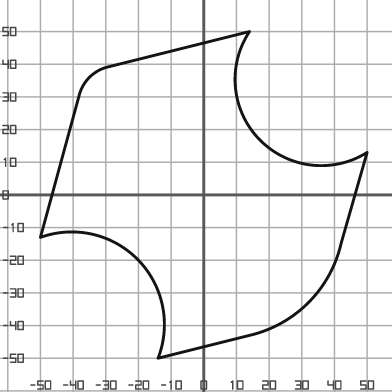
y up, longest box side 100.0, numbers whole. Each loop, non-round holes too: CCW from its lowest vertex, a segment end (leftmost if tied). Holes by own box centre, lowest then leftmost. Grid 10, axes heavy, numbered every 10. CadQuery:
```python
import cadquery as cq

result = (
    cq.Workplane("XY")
    .moveTo(-14.0, -50.0)
    .lineTo(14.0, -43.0)
    .threePointArc((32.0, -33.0), (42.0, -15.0))
    .lineTo(50.0, 13.0)
    .threePointArc((17.0, 17.0), (14.0, 50.0))
    .lineTo(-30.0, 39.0)
    .threePointArc((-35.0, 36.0), (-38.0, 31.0))
    .lineTo(-50.0, -13.0)
    .threePointArc((-20.0, -20.0), (-14.0, -50.0))
    .close()
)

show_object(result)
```